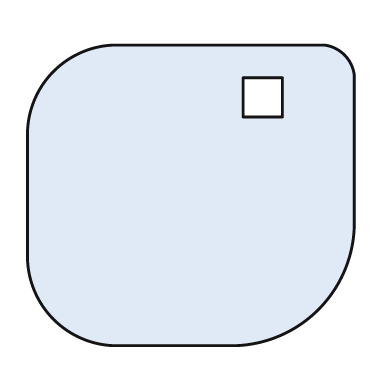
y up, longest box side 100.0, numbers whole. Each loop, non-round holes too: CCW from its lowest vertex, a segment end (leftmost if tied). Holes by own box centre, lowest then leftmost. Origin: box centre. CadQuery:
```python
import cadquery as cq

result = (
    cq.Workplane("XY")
    .moveTo(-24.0, -46.0)
    .lineTo(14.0, -46.0)
    .threePointArc((39.0, -35.0), (50.0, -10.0))
    .lineTo(50.0, 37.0)
    .threePointArc((47.0, 43.0), (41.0, 46.0))
    .lineTo(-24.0, 46.0)
    .threePointArc((-42.0, 38.0), (-50.0, 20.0))
    .lineTo(-50.0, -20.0)
    .threePointArc((-42.0, -38.0), (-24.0, -46.0))
    .close()
    .moveTo(16.0, 24.0)
    .lineTo(28.0, 24.0)
    .lineTo(28.0, 36.0)
    .lineTo(16.0, 36.0)
    .close()
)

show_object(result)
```